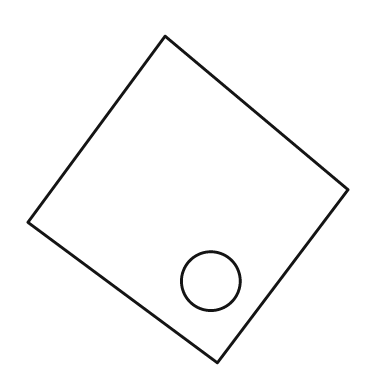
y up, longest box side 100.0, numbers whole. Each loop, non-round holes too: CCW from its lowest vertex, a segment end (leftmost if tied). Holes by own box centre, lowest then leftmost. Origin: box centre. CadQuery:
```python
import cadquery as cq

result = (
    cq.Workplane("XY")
    .moveTo(9.0, -50.0)
    .lineTo(49.0, 3.0)
    .lineTo(-7.0, 50.0)
    .lineTo(-49.0, -7.0)
    .close()
    .moveTo(7.0, -25.0)
    .circle(9.0)
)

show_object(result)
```